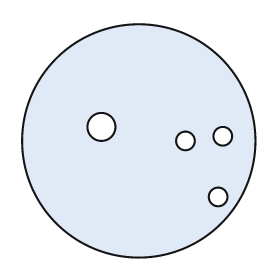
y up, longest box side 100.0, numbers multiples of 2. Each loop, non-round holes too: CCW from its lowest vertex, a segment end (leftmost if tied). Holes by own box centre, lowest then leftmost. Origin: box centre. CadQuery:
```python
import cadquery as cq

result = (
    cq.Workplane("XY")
    .moveTo(0.0, 0.0)
    .circle(50.0)
    .moveTo(34.0, -24.0)
    .circle(4.0)
    .moveTo(20.0, 0.0)
    .circle(4.0)
    .moveTo(36.0, 2.0)
    .circle(4.0)
    .moveTo(-16.0, 6.0)
    .circle(6.0)
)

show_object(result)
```